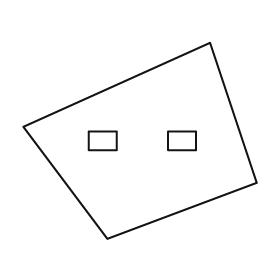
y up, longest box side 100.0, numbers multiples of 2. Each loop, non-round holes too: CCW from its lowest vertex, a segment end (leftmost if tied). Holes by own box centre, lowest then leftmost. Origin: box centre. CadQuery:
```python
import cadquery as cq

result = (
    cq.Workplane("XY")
    .moveTo(-14.0, -42.0)
    .lineTo(50.0, -18.0)
    .lineTo(30.0, 42.0)
    .lineTo(-50.0, 6.0)
    .close()
    .moveTo(-22.0, -4.0)
    .lineTo(-10.0, -4.0)
    .lineTo(-10.0, 4.0)
    .lineTo(-22.0, 4.0)
    .close()
    .moveTo(12.0, -4.0)
    .lineTo(24.0, -4.0)
    .lineTo(24.0, 4.0)
    .lineTo(12.0, 4.0)
    .close()
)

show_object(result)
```